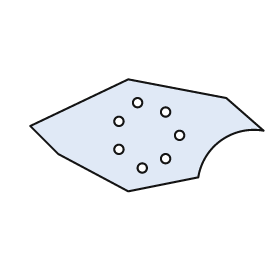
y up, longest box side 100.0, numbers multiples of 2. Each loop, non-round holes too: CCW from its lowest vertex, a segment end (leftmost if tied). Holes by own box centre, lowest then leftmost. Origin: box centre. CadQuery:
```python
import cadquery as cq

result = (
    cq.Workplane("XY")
    .moveTo(-8.0, -24.0)
    .lineTo(22.0, -18.0)
    .threePointArc((32.0, -2.0), (50.0, 2.0))
    .lineTo(34.0, 16.0)
    .lineTo(-8.0, 24.0)
    .lineTo(-50.0, 4.0)
    .lineTo(-38.0, -8.0)
    .close()
    .moveTo(-2.0, -14.0)
    .circle(2.0)
    .moveTo(8.0, -10.0)
    .circle(2.0)
    .moveTo(-12.0, -6.0)
    .circle(2.0)
    .moveTo(14.0, 0.0)
    .circle(2.0)
    .moveTo(-12.0, 6.0)
    .circle(2.0)
    .moveTo(8.0, 10.0)
    .circle(2.0)
    .moveTo(-4.0, 14.0)
    .circle(2.0)
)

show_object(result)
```